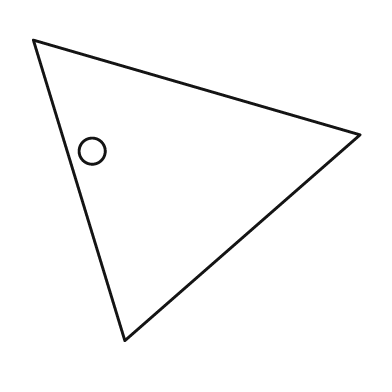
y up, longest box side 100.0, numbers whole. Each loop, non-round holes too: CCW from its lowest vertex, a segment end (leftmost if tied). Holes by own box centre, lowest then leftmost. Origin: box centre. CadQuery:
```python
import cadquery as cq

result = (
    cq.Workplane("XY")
    .moveTo(-22.0, -46.0)
    .lineTo(50.0, 17.0)
    .lineTo(-50.0, 46.0)
    .close()
    .moveTo(-32.0, 12.0)
    .circle(4.0)
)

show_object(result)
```